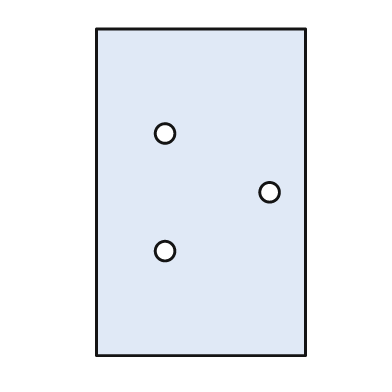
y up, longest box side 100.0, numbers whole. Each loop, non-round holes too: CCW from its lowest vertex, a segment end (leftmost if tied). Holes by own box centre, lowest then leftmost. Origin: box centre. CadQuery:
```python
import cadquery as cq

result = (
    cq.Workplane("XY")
    .moveTo(-32.0, -50.0)
    .lineTo(32.0, -50.0)
    .lineTo(32.0, 50.0)
    .lineTo(-32.0, 50.0)
    .close()
    .moveTo(-11.0, -18.0)
    .circle(3.0)
    .moveTo(21.0, 0.0)
    .circle(3.0)
    .moveTo(-11.0, 18.0)
    .circle(3.0)
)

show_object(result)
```